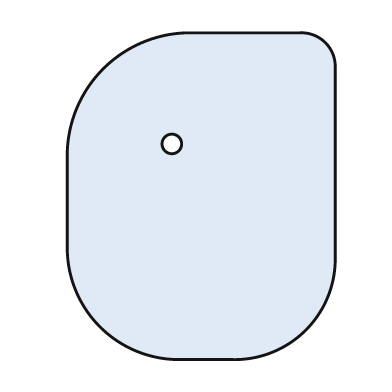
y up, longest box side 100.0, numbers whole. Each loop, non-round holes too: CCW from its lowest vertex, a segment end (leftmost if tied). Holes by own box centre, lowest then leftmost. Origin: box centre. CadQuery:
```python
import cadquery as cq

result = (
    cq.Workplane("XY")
    .moveTo(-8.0, -50.0)
    .lineTo(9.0, -50.0)
    .threePointArc((32.0, -41.0), (41.0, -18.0))
    .lineTo(41.0, 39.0)
    .threePointArc((38.0, 47.0), (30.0, 50.0))
    .lineTo(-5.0, 50.0)
    .threePointArc((-30.0, 39.0), (-41.0, 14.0))
    .lineTo(-41.0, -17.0)
    .threePointArc((-31.0, -40.0), (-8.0, -50.0))
    .close()
    .moveTo(-9.0, 16.0)
    .circle(3.0)
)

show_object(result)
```